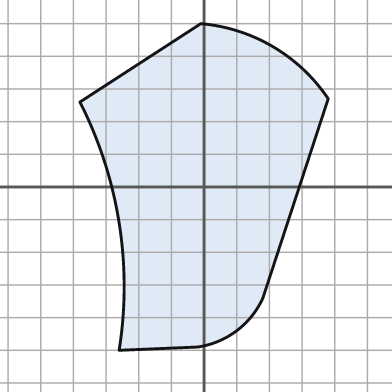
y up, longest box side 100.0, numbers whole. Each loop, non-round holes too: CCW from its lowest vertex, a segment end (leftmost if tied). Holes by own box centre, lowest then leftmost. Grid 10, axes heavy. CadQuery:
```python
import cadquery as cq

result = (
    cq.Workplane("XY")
    .moveTo(-26.0, -50.0)
    .lineTo(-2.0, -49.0)
    .threePointArc((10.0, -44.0), (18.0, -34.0))
    .lineTo(38.0, 27.0)
    .threePointArc((21.0, 43.0), (-1.0, 50.0))
    .lineTo(-38.0, 26.0)
    .threePointArc((-26.0, -11.0), (-26.0, -50.0))
    .close()
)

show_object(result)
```